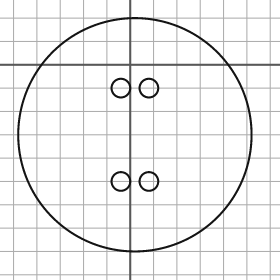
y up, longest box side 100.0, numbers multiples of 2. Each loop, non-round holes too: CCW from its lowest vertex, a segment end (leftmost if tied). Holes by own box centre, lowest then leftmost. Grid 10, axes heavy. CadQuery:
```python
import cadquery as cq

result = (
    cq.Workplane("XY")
    .moveTo(2.0, -30.0)
    .circle(50.0)
    .moveTo(-4.0, -50.0)
    .circle(4.0)
    .moveTo(8.0, -50.0)
    .circle(4.0)
    .moveTo(-4.0, -10.0)
    .circle(4.0)
    .moveTo(8.0, -10.0)
    .circle(4.0)
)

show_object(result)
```